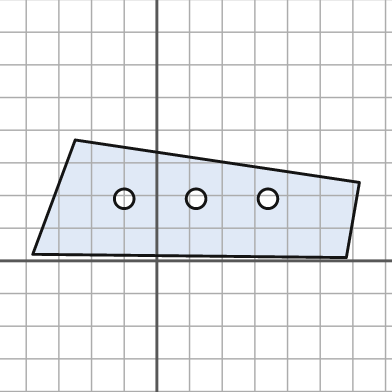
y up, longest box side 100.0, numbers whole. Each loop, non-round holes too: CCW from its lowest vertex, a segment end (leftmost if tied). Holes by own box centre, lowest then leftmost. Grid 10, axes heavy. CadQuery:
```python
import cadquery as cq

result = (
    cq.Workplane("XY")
    .moveTo(58.0, 1.0)
    .lineTo(62.0, 24.0)
    .lineTo(-25.0, 37.0)
    .lineTo(-38.0, 2.0)
    .close()
    .moveTo(-10.0, 19.0)
    .circle(3.0)
    .moveTo(12.0, 19.0)
    .circle(3.0)
    .moveTo(34.0, 19.0)
    .circle(3.0)
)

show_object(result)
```